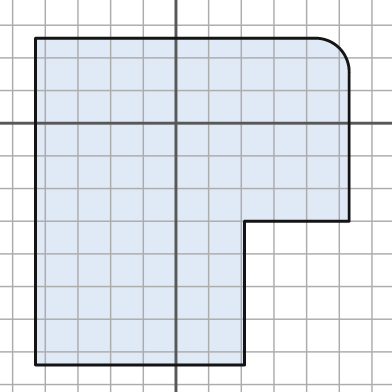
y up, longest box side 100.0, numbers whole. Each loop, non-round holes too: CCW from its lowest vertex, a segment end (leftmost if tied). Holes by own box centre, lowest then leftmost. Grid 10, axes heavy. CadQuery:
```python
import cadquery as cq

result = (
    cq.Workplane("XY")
    .moveTo(-43.0, -74.0)
    .lineTo(21.0, -74.0)
    .lineTo(21.0, -30.0)
    .lineTo(53.0, -30.0)
    .lineTo(53.0, 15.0)
    .threePointArc((50.0, 23.0), (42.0, 26.0))
    .lineTo(-43.0, 26.0)
    .close()
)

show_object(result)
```